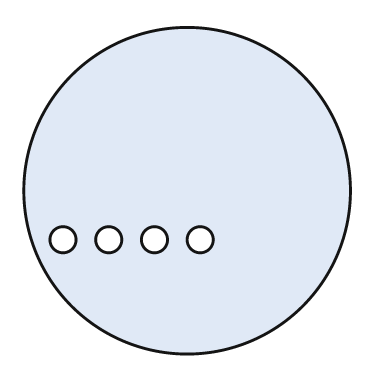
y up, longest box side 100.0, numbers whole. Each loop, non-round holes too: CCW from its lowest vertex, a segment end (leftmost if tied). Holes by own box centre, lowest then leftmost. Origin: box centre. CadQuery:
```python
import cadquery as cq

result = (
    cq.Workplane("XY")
    .moveTo(0.0, 0.0)
    .circle(50.0)
    .moveTo(-38.0, -15.0)
    .circle(4.0)
    .moveTo(-24.0, -15.0)
    .circle(4.0)
    .moveTo(-10.0, -15.0)
    .circle(4.0)
    .moveTo(4.0, -15.0)
    .circle(4.0)
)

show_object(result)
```